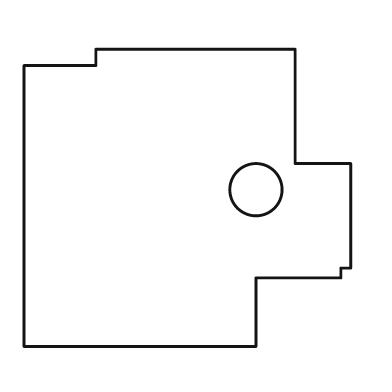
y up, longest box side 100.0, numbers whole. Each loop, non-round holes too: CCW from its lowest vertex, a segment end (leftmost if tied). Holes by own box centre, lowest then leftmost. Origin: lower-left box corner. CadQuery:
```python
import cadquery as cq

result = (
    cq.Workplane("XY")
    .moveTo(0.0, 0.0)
    .lineTo(71.0, 0.0)
    .lineTo(71.0, 21.0)
    .lineTo(97.0, 21.0)
    .lineTo(97.0, 24.0)
    .lineTo(100.0, 24.0)
    .lineTo(100.0, 56.0)
    .lineTo(83.0, 56.0)
    .lineTo(83.0, 91.0)
    .lineTo(22.0, 91.0)
    .lineTo(22.0, 86.0)
    .lineTo(0.0, 86.0)
    .close()
    .moveTo(71.0, 48.0)
    .circle(8.0)
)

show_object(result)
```